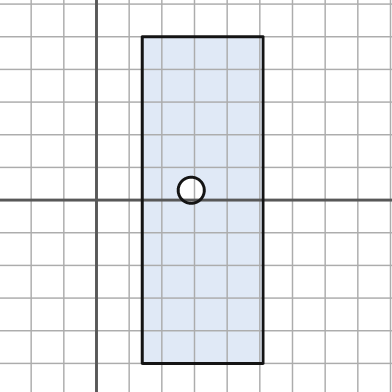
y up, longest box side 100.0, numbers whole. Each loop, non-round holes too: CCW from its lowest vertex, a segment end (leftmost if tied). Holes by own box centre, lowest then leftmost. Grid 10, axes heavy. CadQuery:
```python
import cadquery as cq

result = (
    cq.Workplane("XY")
    .moveTo(14.0, -50.0)
    .lineTo(51.0, -50.0)
    .lineTo(51.0, 50.0)
    .lineTo(14.0, 50.0)
    .close()
    .moveTo(29.0, 3.0)
    .circle(4.0)
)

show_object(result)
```